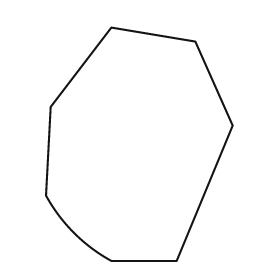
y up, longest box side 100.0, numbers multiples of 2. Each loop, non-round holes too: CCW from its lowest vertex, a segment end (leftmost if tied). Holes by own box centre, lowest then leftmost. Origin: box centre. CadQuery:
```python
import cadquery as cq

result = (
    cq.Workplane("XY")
    .moveTo(-12.0, -50.0)
    .lineTo(16.0, -50.0)
    .lineTo(40.0, 8.0)
    .lineTo(24.0, 44.0)
    .lineTo(-12.0, 50.0)
    .lineTo(-38.0, 16.0)
    .lineTo(-40.0, -22.0)
    .threePointArc((-28.0, -38.0), (-12.0, -50.0))
    .close()
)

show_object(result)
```